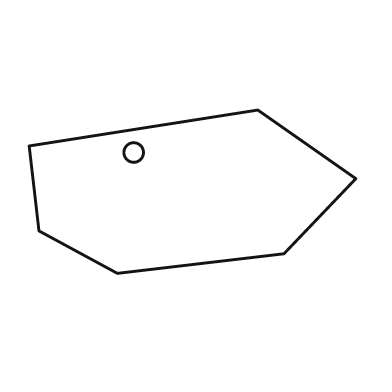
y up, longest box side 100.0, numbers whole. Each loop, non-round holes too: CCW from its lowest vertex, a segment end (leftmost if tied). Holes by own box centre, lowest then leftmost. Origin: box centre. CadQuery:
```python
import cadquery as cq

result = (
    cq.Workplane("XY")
    .moveTo(-23.0, -25.0)
    .lineTo(28.0, -19.0)
    .lineTo(50.0, 4.0)
    .lineTo(20.0, 25.0)
    .lineTo(-50.0, 14.0)
    .lineTo(-47.0, -12.0)
    .close()
    .moveTo(-18.0, 12.0)
    .circle(3.0)
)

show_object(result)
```